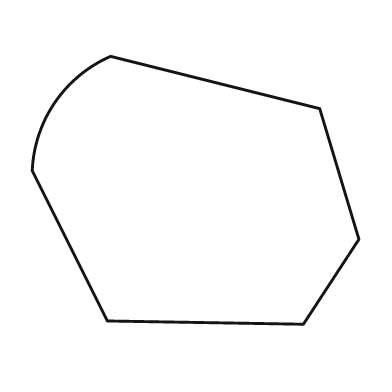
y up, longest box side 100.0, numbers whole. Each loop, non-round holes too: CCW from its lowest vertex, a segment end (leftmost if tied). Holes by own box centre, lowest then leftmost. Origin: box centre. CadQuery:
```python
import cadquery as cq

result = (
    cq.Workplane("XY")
    .moveTo(33.0, -41.0)
    .lineTo(50.0, -15.0)
    .lineTo(38.0, 25.0)
    .lineTo(-26.0, 41.0)
    .threePointArc((-43.0, 27.0), (-50.0, 6.0))
    .lineTo(-27.0, -40.0)
    .close()
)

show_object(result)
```